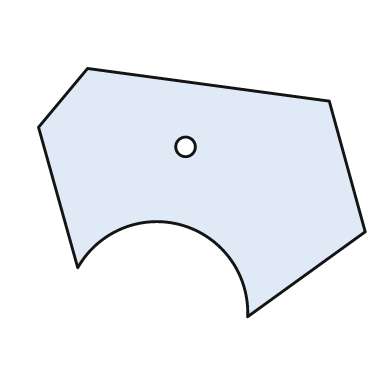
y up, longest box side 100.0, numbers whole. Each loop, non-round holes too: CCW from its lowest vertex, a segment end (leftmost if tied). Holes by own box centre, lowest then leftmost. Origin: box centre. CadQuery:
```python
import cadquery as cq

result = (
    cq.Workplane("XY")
    .moveTo(14.0, -38.0)
    .lineTo(50.0, -12.0)
    .lineTo(39.0, 28.0)
    .lineTo(-35.0, 38.0)
    .lineTo(-50.0, 20.0)
    .lineTo(-38.0, -23.0)
    .threePointArc((-6.0, -10.0), (14.0, -38.0))
    .close()
    .moveTo(-5.0, 14.0)
    .circle(3.0)
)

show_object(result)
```